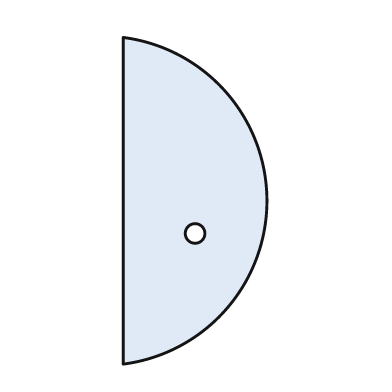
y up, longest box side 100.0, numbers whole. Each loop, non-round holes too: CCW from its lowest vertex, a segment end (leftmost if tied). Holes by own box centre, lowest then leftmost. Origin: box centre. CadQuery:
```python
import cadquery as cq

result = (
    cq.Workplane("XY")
    .moveTo(-22.0, -50.0)
    .threePointArc((22.0, 0.0), (-22.0, 50.0))
    .close()
    .moveTo(0.0, -10.0)
    .circle(3.0)
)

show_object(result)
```